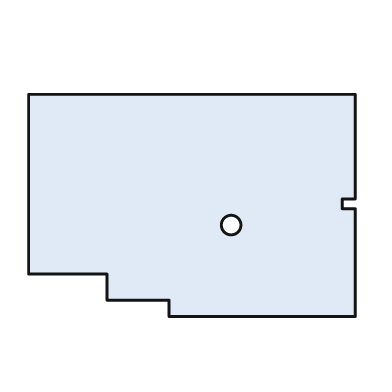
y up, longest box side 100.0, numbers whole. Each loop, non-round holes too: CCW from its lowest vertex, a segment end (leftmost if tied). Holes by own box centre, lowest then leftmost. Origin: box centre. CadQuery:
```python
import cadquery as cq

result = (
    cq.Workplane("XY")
    .moveTo(-7.0, -34.0)
    .lineTo(50.0, -34.0)
    .lineTo(50.0, -1.0)
    .lineTo(46.0, -1.0)
    .lineTo(46.0, 2.0)
    .lineTo(50.0, 2.0)
    .lineTo(50.0, 34.0)
    .lineTo(-50.0, 34.0)
    .lineTo(-50.0, -21.0)
    .lineTo(-26.0, -21.0)
    .lineTo(-26.0, -29.0)
    .lineTo(-7.0, -29.0)
    .close()
    .moveTo(12.0, -6.0)
    .circle(3.0)
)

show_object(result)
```